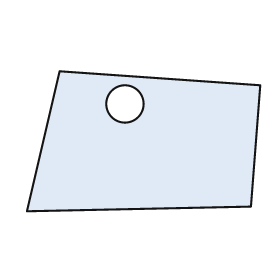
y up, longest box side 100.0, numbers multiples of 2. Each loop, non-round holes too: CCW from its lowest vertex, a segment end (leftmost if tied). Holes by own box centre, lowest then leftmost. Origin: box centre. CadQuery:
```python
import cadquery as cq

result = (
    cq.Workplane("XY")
    .moveTo(-50.0, -30.0)
    .lineTo(46.0, -28.0)
    .lineTo(50.0, 24.0)
    .lineTo(-36.0, 30.0)
    .close()
    .moveTo(-8.0, 16.0)
    .circle(8.0)
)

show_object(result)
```